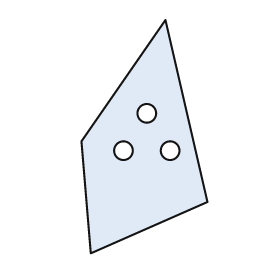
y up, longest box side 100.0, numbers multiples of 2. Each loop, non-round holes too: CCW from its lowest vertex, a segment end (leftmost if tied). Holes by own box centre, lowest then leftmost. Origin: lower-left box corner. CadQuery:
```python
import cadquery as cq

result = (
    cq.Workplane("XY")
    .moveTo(4.0, 0.0)
    .lineTo(54.0, 22.0)
    .lineTo(36.0, 100.0)
    .lineTo(0.0, 48.0)
    .close()
    .moveTo(18.0, 44.0)
    .circle(4.0)
    .moveTo(38.0, 44.0)
    .circle(4.0)
    .moveTo(28.0, 60.0)
    .circle(4.0)
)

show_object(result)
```